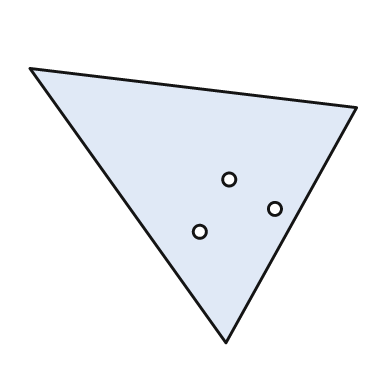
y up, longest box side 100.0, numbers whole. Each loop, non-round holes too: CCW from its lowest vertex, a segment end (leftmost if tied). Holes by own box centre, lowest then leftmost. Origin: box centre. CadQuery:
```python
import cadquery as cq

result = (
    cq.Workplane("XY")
    .moveTo(10.0, -42.0)
    .lineTo(50.0, 30.0)
    .lineTo(-50.0, 42.0)
    .close()
    .moveTo(2.0, -8.0)
    .circle(2.0)
    .moveTo(25.0, -1.0)
    .circle(2.0)
    .moveTo(11.0, 8.0)
    .circle(2.0)
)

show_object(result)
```